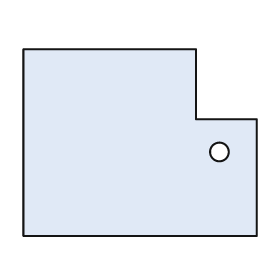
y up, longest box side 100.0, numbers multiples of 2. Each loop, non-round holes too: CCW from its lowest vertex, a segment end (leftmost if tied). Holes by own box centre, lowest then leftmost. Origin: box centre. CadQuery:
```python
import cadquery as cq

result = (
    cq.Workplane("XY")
    .moveTo(-50.0, -40.0)
    .lineTo(50.0, -40.0)
    .lineTo(50.0, 10.0)
    .lineTo(24.0, 10.0)
    .lineTo(24.0, 40.0)
    .lineTo(-50.0, 40.0)
    .close()
    .moveTo(34.0, -4.0)
    .circle(4.0)
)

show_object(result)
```